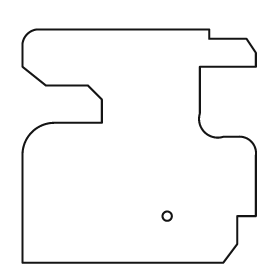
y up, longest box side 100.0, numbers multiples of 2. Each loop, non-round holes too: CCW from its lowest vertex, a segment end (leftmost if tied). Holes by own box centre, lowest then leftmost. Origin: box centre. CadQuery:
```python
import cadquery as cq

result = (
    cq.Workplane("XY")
    .moveTo(-50.0, -50.0)
    .lineTo(36.0, -50.0)
    .lineTo(42.0, -42.0)
    .lineTo(42.0, -30.0)
    .lineTo(50.0, -30.0)
    .lineTo(50.0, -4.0)
    .threePointArc((48.0, 2.0), (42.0, 4.0))
    .lineTo(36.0, 4.0)
    .threePointArc((28.0, 6.0), (26.0, 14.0))
    .lineTo(26.0, 34.0)
    .lineTo(50.0, 34.0)
    .lineTo(50.0, 40.0)
    .lineTo(46.0, 46.0)
    .lineTo(30.0, 46.0)
    .lineTo(30.0, 50.0)
    .lineTo(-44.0, 50.0)
    .threePointArc((-48.0, 48.0), (-50.0, 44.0))
    .lineTo(-50.0, 34.0)
    .lineTo(-40.0, 26.0)
    .lineTo(-22.0, 26.0)
    .lineTo(-16.0, 20.0)
    .lineTo(-16.0, 10.0)
    .lineTo(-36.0, 10.0)
    .threePointArc((-46.0, 6.0), (-50.0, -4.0))
    .close()
    .moveTo(12.0, -30.0)
    .circle(2.0)
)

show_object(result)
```